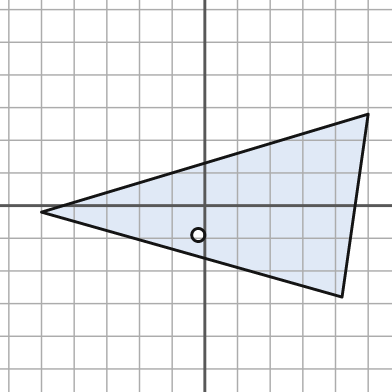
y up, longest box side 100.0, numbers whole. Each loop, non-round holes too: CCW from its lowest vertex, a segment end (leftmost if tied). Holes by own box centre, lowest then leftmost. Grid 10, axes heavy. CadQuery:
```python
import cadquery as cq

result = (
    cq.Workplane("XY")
    .moveTo(42.0, -28.0)
    .lineTo(50.0, 28.0)
    .lineTo(-50.0, -2.0)
    .close()
    .moveTo(-2.0, -9.0)
    .circle(2.0)
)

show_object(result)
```